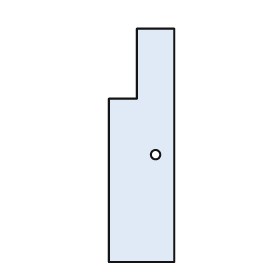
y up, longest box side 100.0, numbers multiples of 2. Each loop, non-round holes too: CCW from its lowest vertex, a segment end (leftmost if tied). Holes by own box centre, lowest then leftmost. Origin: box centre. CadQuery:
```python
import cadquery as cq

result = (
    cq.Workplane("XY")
    .moveTo(-14.0, -50.0)
    .lineTo(14.0, -50.0)
    .lineTo(14.0, 50.0)
    .lineTo(-2.0, 50.0)
    .lineTo(-2.0, 20.0)
    .lineTo(-14.0, 20.0)
    .close()
    .moveTo(6.0, -4.0)
    .circle(2.0)
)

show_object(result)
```